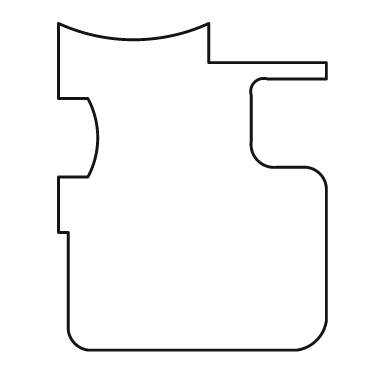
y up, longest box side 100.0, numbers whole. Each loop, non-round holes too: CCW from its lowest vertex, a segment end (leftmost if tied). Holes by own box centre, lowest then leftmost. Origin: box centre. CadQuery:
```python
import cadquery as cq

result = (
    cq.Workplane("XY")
    .moveTo(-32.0, -50.0)
    .lineTo(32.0, -50.0)
    .threePointArc((38.0, -47.0), (41.0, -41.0))
    .lineTo(41.0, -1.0)
    .threePointArc((39.0, 4.0), (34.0, 6.0))
    .lineTo(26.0, 6.0)
    .threePointArc((20.0, 8.0), (18.0, 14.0))
    .lineTo(18.0, 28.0)
    .threePointArc((19.0, 32.0), (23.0, 33.0))
    .lineTo(41.0, 33.0)
    .lineTo(41.0, 38.0)
    .lineTo(5.0, 38.0)
    .lineTo(5.0, 50.0)
    .threePointArc((-18.0, 45.0), (-41.0, 50.0))
    .lineTo(-41.0, 27.0)
    .lineTo(-32.0, 27.0)
    .threePointArc((-29.0, 15.0), (-32.0, 3.0))
    .lineTo(-41.0, 3.0)
    .lineTo(-41.0, -14.0)
    .lineTo(-38.0, -14.0)
    .lineTo(-38.0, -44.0)
    .threePointArc((-36.0, -48.0), (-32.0, -50.0))
    .close()
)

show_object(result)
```